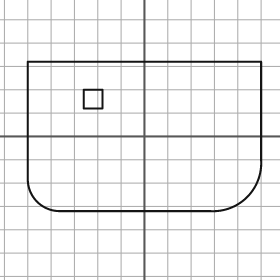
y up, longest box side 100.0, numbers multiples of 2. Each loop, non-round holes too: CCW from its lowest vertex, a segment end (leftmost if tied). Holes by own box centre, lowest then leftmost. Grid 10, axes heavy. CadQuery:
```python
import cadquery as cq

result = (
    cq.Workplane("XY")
    .moveTo(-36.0, -32.0)
    .lineTo(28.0, -32.0)
    .threePointArc((44.0, -26.0), (50.0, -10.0))
    .lineTo(50.0, 32.0)
    .lineTo(-50.0, 32.0)
    .lineTo(-50.0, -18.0)
    .threePointArc((-46.0, -28.0), (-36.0, -32.0))
    .close()
    .moveTo(-26.0, 12.0)
    .lineTo(-18.0, 12.0)
    .lineTo(-18.0, 20.0)
    .lineTo(-26.0, 20.0)
    .close()
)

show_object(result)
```